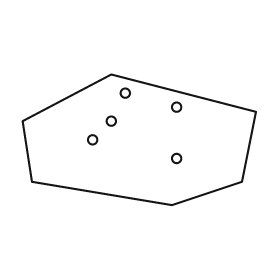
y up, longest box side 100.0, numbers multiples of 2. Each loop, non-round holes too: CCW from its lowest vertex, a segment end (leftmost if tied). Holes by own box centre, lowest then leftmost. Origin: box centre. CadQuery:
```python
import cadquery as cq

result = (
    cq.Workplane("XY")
    .moveTo(14.0, -28.0)
    .lineTo(44.0, -18.0)
    .lineTo(50.0, 12.0)
    .lineTo(-12.0, 28.0)
    .lineTo(-50.0, 8.0)
    .lineTo(-46.0, -18.0)
    .close()
    .moveTo(16.0, -8.0)
    .circle(2.0)
    .moveTo(-20.0, 0.0)
    .circle(2.0)
    .moveTo(-12.0, 8.0)
    .circle(2.0)
    .moveTo(16.0, 14.0)
    .circle(2.0)
    .moveTo(-6.0, 20.0)
    .circle(2.0)
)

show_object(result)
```